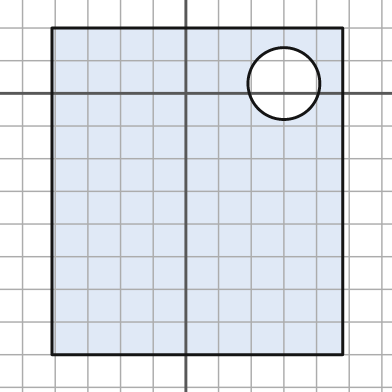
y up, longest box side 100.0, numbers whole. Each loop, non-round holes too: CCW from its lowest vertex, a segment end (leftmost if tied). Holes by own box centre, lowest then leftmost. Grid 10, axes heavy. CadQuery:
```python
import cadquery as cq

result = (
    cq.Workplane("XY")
    .moveTo(-41.0, -80.0)
    .lineTo(48.0, -80.0)
    .lineTo(48.0, 20.0)
    .lineTo(-41.0, 20.0)
    .close()
    .moveTo(30.0, 3.0)
    .circle(11.0)
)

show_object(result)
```